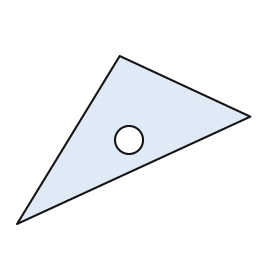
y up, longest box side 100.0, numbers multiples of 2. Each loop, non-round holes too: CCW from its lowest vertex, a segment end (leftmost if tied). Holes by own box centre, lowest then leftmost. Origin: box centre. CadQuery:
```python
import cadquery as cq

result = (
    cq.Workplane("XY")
    .moveTo(-50.0, -36.0)
    .lineTo(50.0, 10.0)
    .lineTo(-6.0, 36.0)
    .close()
    .moveTo(-2.0, 0.0)
    .circle(6.0)
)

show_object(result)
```